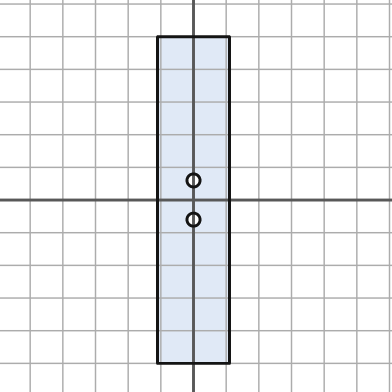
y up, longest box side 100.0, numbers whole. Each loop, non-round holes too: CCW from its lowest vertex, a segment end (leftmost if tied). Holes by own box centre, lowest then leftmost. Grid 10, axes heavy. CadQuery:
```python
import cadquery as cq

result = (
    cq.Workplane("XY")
    .moveTo(-11.0, -50.0)
    .lineTo(11.0, -50.0)
    .lineTo(11.0, 50.0)
    .lineTo(-11.0, 50.0)
    .close()
    .moveTo(0.0, -6.0)
    .circle(2.0)
    .moveTo(0.0, 6.0)
    .circle(2.0)
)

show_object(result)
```